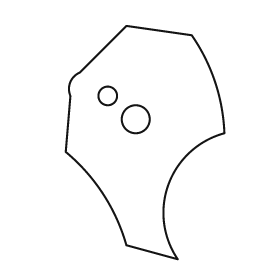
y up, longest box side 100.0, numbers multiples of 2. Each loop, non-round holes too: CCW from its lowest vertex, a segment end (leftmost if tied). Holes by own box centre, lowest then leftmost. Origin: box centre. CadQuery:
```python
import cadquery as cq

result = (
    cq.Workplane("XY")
    .moveTo(14.0, -50.0)
    .threePointArc((10.0, -18.0), (34.0, 4.0))
    .threePointArc((30.0, 26.0), (20.0, 46.0))
    .lineTo(-8.0, 50.0)
    .lineTo(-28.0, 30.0)
    .threePointArc((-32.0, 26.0), (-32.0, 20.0))
    .lineTo(-34.0, -4.0)
    .threePointArc((-18.0, -22.0), (-8.0, -44.0))
    .close()
    .moveTo(-4.0, 10.0)
    .circle(6.0)
    .moveTo(-16.0, 20.0)
    .circle(4.0)
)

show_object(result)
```